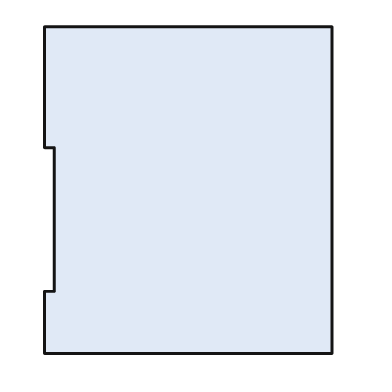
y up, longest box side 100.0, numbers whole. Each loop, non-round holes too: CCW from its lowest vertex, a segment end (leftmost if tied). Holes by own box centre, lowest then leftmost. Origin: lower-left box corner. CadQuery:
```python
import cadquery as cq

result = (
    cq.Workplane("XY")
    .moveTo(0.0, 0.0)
    .lineTo(88.0, 0.0)
    .lineTo(88.0, 100.0)
    .lineTo(0.0, 100.0)
    .lineTo(0.0, 63.0)
    .lineTo(3.0, 63.0)
    .lineTo(3.0, 19.0)
    .lineTo(0.0, 19.0)
    .close()
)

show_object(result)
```